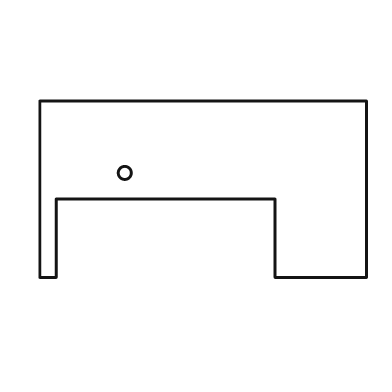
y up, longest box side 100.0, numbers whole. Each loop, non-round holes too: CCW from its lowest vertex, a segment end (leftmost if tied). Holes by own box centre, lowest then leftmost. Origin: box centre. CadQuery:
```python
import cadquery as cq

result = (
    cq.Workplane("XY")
    .moveTo(-50.0, -27.0)
    .lineTo(-45.0, -27.0)
    .lineTo(-45.0, -3.0)
    .lineTo(22.0, -3.0)
    .lineTo(22.0, -27.0)
    .lineTo(50.0, -27.0)
    .lineTo(50.0, 27.0)
    .lineTo(-50.0, 27.0)
    .close()
    .moveTo(-24.0, 5.0)
    .circle(2.0)
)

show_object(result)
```